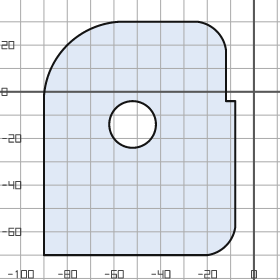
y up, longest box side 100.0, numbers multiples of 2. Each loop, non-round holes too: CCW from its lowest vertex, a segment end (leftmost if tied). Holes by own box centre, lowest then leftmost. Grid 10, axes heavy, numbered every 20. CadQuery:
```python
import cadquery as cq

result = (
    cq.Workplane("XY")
    .moveTo(-90.0, -70.0)
    .lineTo(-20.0, -70.0)
    .threePointArc((-12.0, -66.0), (-8.0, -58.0))
    .lineTo(-8.0, -4.0)
    .lineTo(-12.0, -4.0)
    .lineTo(-12.0, 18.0)
    .threePointArc((-16.0, 26.0), (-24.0, 30.0))
    .lineTo(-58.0, 30.0)
    .threePointArc((-80.0, 20.0), (-90.0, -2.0))
    .close()
    .moveTo(-52.0, -14.0)
    .circle(10.0)
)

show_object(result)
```